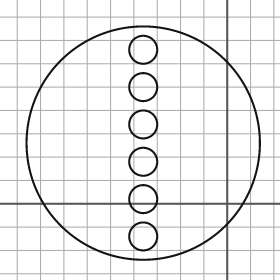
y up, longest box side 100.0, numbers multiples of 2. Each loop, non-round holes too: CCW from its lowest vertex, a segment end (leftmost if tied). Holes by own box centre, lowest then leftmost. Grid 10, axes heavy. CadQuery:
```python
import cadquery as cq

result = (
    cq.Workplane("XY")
    .moveTo(-36.0, 26.0)
    .circle(50.0)
    .moveTo(-36.0, -14.0)
    .circle(6.0)
    .moveTo(-36.0, 2.0)
    .circle(6.0)
    .moveTo(-36.0, 18.0)
    .circle(6.0)
    .moveTo(-36.0, 34.0)
    .circle(6.0)
    .moveTo(-36.0, 50.0)
    .circle(6.0)
    .moveTo(-36.0, 66.0)
    .circle(6.0)
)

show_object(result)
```